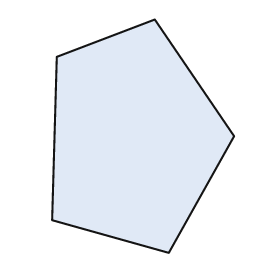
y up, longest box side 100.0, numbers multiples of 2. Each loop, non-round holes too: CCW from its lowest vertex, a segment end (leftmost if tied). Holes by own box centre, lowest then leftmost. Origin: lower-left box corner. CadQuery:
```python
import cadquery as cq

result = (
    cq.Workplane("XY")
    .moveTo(50.0, 0.0)
    .lineTo(78.0, 50.0)
    .lineTo(44.0, 100.0)
    .lineTo(2.0, 84.0)
    .lineTo(0.0, 14.0)
    .close()
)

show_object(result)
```